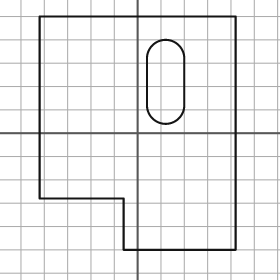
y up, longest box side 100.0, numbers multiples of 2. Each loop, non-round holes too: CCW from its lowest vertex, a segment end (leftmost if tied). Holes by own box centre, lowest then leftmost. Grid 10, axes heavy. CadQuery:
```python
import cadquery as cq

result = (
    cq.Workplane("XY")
    .moveTo(-6.0, -50.0)
    .lineTo(42.0, -50.0)
    .lineTo(42.0, 50.0)
    .lineTo(-42.0, 50.0)
    .lineTo(-42.0, -28.0)
    .lineTo(-6.0, -28.0)
    .close()
    .moveTo(4.0, 12.0)
    .threePointArc((12.0, 4.0), (20.0, 12.0))
    .lineTo(20.0, 32.0)
    .threePointArc((12.0, 40.0), (4.0, 32.0))
    .close()
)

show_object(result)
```